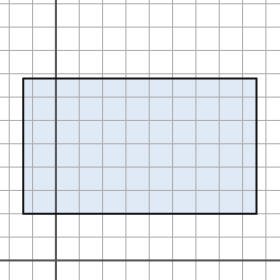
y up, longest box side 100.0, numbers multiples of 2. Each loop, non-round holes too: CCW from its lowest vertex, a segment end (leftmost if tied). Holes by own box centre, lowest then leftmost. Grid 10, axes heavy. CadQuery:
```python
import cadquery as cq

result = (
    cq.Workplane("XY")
    .moveTo(-14.0, 20.0)
    .lineTo(86.0, 20.0)
    .lineTo(86.0, 78.0)
    .lineTo(-14.0, 78.0)
    .close()
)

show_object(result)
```